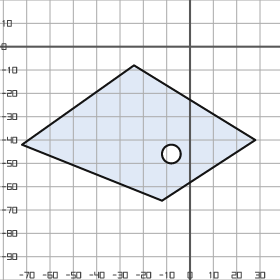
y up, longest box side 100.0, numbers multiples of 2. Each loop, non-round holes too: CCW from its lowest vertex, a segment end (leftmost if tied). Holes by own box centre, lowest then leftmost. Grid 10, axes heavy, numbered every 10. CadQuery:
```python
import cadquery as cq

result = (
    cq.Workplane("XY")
    .moveTo(-12.0, -66.0)
    .lineTo(28.0, -40.0)
    .lineTo(-24.0, -8.0)
    .lineTo(-72.0, -42.0)
    .close()
    .moveTo(-8.0, -46.0)
    .circle(4.0)
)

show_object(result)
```